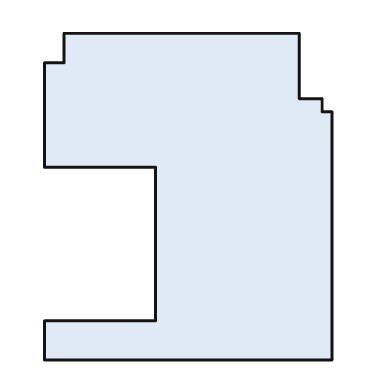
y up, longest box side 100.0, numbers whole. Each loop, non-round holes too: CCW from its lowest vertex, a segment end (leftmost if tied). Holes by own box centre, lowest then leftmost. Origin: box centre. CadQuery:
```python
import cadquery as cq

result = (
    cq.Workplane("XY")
    .moveTo(-44.0, -50.0)
    .lineTo(44.0, -50.0)
    .lineTo(44.0, 26.0)
    .lineTo(41.0, 26.0)
    .lineTo(41.0, 30.0)
    .lineTo(34.0, 30.0)
    .lineTo(34.0, 50.0)
    .lineTo(-38.0, 50.0)
    .lineTo(-38.0, 41.0)
    .lineTo(-44.0, 41.0)
    .lineTo(-44.0, 9.0)
    .lineTo(-10.0, 9.0)
    .lineTo(-10.0, -38.0)
    .lineTo(-44.0, -38.0)
    .close()
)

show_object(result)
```